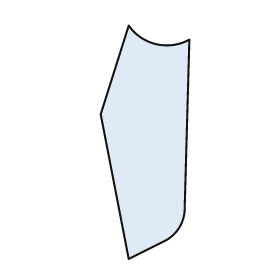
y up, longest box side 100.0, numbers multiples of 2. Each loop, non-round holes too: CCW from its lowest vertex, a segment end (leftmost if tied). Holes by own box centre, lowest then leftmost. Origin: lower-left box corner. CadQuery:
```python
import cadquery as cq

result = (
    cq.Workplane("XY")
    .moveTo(12.0, 0.0)
    .lineTo(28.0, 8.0)
    .threePointArc((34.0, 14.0), (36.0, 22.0))
    .lineTo(38.0, 94.0)
    .threePointArc((24.0, 92.0), (12.0, 100.0))
    .lineTo(0.0, 62.0)
    .close()
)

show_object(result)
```